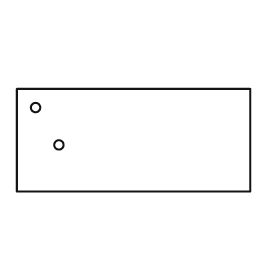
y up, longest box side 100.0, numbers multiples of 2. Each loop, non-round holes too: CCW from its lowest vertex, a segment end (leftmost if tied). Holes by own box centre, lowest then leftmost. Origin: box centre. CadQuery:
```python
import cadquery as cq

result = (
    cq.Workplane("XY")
    .moveTo(-50.0, -22.0)
    .lineTo(50.0, -22.0)
    .lineTo(50.0, 22.0)
    .lineTo(-50.0, 22.0)
    .close()
    .moveTo(-32.0, -2.0)
    .circle(2.0)
    .moveTo(-42.0, 14.0)
    .circle(2.0)
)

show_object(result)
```